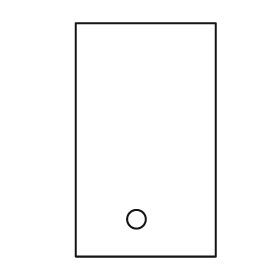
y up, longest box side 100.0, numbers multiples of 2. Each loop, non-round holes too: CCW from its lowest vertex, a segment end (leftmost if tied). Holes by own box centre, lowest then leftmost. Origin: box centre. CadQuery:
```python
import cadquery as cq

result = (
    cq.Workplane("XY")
    .moveTo(-30.0, -50.0)
    .lineTo(30.0, -50.0)
    .lineTo(30.0, 50.0)
    .lineTo(-30.0, 50.0)
    .close()
    .moveTo(-4.0, -34.0)
    .circle(4.0)
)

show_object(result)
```